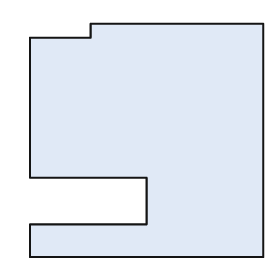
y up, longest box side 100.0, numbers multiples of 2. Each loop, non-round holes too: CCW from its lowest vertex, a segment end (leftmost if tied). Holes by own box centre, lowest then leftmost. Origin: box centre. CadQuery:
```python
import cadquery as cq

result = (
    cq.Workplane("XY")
    .moveTo(-50.0, -50.0)
    .lineTo(50.0, -50.0)
    .lineTo(50.0, 50.0)
    .lineTo(-24.0, 50.0)
    .lineTo(-24.0, 44.0)
    .lineTo(-50.0, 44.0)
    .lineTo(-50.0, -16.0)
    .lineTo(0.0, -16.0)
    .lineTo(0.0, -36.0)
    .lineTo(-50.0, -36.0)
    .close()
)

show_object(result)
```